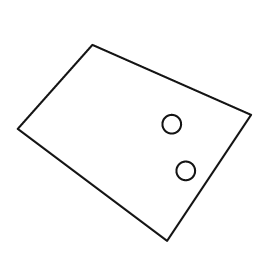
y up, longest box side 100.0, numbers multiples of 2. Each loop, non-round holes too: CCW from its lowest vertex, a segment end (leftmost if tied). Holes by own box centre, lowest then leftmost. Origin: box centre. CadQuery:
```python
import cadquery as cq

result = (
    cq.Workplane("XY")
    .moveTo(14.0, -42.0)
    .lineTo(50.0, 12.0)
    .lineTo(-18.0, 42.0)
    .lineTo(-50.0, 6.0)
    .close()
    .moveTo(22.0, -12.0)
    .circle(4.0)
    .moveTo(16.0, 8.0)
    .circle(4.0)
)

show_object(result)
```